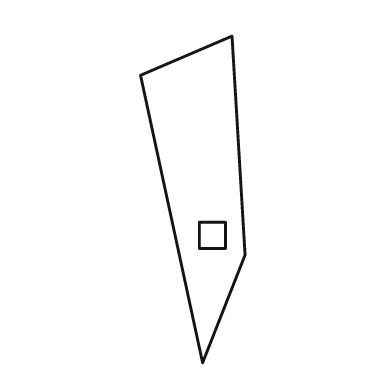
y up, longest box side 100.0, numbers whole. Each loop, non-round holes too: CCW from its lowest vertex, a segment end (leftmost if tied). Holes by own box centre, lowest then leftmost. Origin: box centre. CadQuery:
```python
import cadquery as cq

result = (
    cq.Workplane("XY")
    .moveTo(3.0, -50.0)
    .lineTo(16.0, -17.0)
    .lineTo(12.0, 50.0)
    .lineTo(-16.0, 38.0)
    .close()
    .moveTo(2.0, -15.0)
    .lineTo(10.0, -15.0)
    .lineTo(10.0, -7.0)
    .lineTo(2.0, -7.0)
    .close()
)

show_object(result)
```